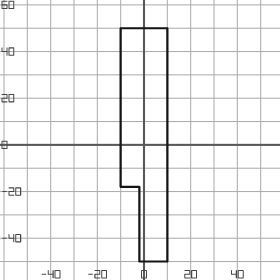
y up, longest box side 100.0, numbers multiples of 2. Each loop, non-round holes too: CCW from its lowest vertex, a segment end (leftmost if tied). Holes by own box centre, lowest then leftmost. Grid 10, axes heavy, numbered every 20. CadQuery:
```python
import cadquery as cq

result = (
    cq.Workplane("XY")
    .moveTo(-2.0, -50.0)
    .lineTo(10.0, -50.0)
    .lineTo(10.0, 50.0)
    .lineTo(-10.0, 50.0)
    .lineTo(-10.0, -18.0)
    .lineTo(-2.0, -18.0)
    .close()
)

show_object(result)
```